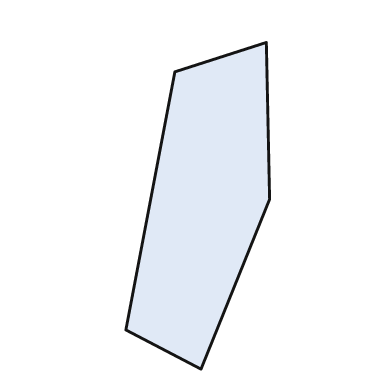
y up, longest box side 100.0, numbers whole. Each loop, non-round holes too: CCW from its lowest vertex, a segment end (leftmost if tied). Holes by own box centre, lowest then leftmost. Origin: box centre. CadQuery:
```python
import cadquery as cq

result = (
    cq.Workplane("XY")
    .moveTo(1.0, -50.0)
    .lineTo(22.0, 2.0)
    .lineTo(21.0, 50.0)
    .lineTo(-7.0, 41.0)
    .lineTo(-22.0, -38.0)
    .close()
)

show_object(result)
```